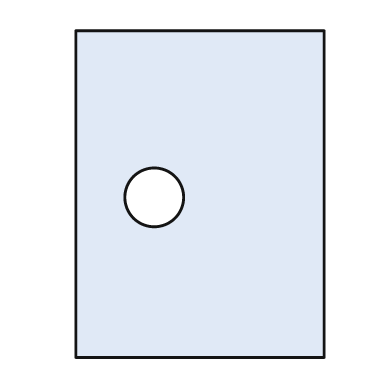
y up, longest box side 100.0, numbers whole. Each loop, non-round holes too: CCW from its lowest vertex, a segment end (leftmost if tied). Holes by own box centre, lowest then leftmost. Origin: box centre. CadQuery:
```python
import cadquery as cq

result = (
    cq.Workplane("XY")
    .moveTo(-38.0, -50.0)
    .lineTo(38.0, -50.0)
    .lineTo(38.0, 50.0)
    .lineTo(-38.0, 50.0)
    .close()
    .moveTo(-14.0, -1.0)
    .circle(9.0)
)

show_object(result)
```